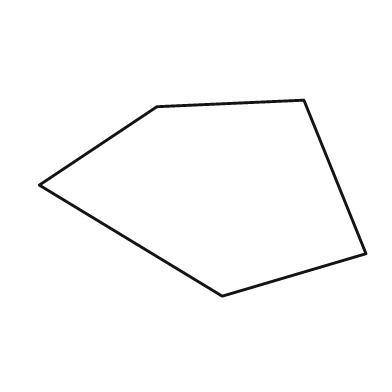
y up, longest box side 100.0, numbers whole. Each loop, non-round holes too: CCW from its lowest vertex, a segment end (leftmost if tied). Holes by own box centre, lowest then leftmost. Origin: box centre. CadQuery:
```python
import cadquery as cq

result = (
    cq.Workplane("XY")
    .moveTo(6.0, -30.0)
    .lineTo(50.0, -17.0)
    .lineTo(31.0, 30.0)
    .lineTo(-14.0, 28.0)
    .lineTo(-50.0, 4.0)
    .close()
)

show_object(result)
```